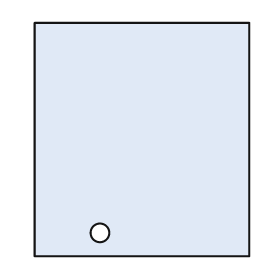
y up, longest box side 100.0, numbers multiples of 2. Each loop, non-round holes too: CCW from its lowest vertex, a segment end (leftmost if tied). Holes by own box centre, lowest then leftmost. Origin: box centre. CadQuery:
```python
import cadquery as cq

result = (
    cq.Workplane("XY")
    .moveTo(-46.0, -50.0)
    .lineTo(46.0, -50.0)
    .lineTo(46.0, 50.0)
    .lineTo(-46.0, 50.0)
    .close()
    .moveTo(-18.0, -40.0)
    .circle(4.0)
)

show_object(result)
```